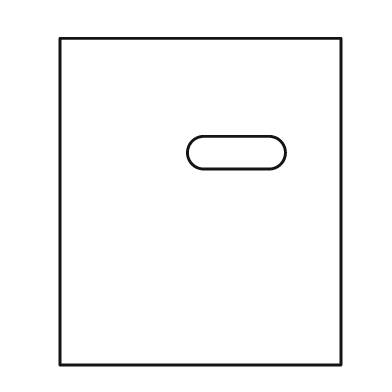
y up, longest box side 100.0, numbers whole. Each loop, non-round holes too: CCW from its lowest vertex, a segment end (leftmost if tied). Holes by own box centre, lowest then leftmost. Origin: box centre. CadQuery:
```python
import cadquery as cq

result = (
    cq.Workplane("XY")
    .moveTo(-43.0, -50.0)
    .lineTo(43.0, -50.0)
    .lineTo(43.0, 50.0)
    .lineTo(-43.0, 50.0)
    .close()
    .moveTo(1.0, 10.0)
    .lineTo(21.0, 10.0)
    .threePointArc((26.0, 15.0), (21.0, 20.0))
    .lineTo(1.0, 20.0)
    .threePointArc((-4.0, 15.0), (1.0, 10.0))
    .close()
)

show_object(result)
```